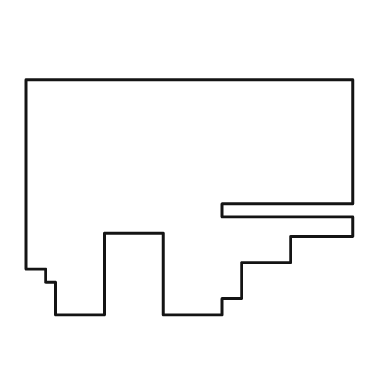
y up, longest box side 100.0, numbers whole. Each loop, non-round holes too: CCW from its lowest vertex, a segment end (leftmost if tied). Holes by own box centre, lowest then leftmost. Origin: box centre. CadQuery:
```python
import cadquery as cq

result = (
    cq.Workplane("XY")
    .moveTo(-41.0, -36.0)
    .lineTo(-26.0, -36.0)
    .lineTo(-26.0, -11.0)
    .lineTo(-8.0, -11.0)
    .lineTo(-8.0, -36.0)
    .lineTo(10.0, -36.0)
    .lineTo(10.0, -31.0)
    .lineTo(16.0, -31.0)
    .lineTo(16.0, -20.0)
    .lineTo(31.0, -20.0)
    .lineTo(31.0, -12.0)
    .lineTo(50.0, -12.0)
    .lineTo(50.0, -6.0)
    .lineTo(10.0, -6.0)
    .lineTo(10.0, -2.0)
    .lineTo(50.0, -2.0)
    .lineTo(50.0, 36.0)
    .lineTo(-50.0, 36.0)
    .lineTo(-50.0, -22.0)
    .lineTo(-44.0, -22.0)
    .lineTo(-44.0, -26.0)
    .lineTo(-41.0, -26.0)
    .close()
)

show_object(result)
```